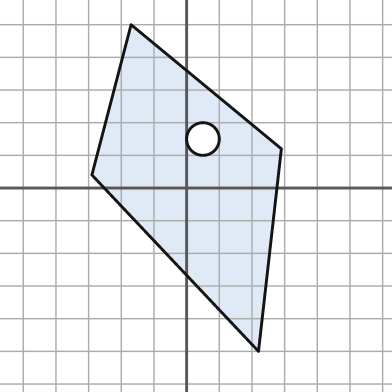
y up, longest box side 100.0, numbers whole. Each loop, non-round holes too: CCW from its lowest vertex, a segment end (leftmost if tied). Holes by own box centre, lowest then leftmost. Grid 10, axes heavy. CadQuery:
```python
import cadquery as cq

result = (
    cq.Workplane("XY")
    .moveTo(22.0, -50.0)
    .lineTo(29.0, 12.0)
    .lineTo(-17.0, 50.0)
    .lineTo(-29.0, 4.0)
    .close()
    .moveTo(5.0, 15.0)
    .circle(5.0)
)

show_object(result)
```